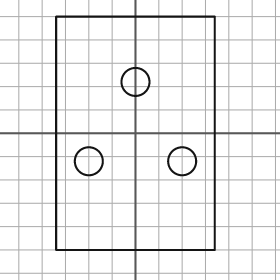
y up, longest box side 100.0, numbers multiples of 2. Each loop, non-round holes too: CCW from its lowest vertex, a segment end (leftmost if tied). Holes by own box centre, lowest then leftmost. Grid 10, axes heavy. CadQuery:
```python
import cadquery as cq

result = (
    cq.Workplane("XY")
    .moveTo(-34.0, -50.0)
    .lineTo(34.0, -50.0)
    .lineTo(34.0, 50.0)
    .lineTo(-34.0, 50.0)
    .close()
    .moveTo(-20.0, -12.0)
    .circle(6.0)
    .moveTo(20.0, -12.0)
    .circle(6.0)
    .moveTo(0.0, 22.0)
    .circle(6.0)
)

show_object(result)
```